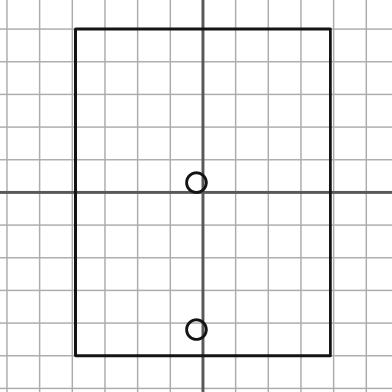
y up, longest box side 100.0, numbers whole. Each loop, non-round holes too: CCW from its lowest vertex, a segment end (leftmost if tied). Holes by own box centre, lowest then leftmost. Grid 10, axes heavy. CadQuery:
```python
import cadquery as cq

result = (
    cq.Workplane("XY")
    .moveTo(-39.0, -50.0)
    .lineTo(39.0, -50.0)
    .lineTo(39.0, 50.0)
    .lineTo(-39.0, 50.0)
    .close()
    .moveTo(-2.0, -42.0)
    .circle(3.0)
    .moveTo(-2.0, 3.0)
    .circle(3.0)
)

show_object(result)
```